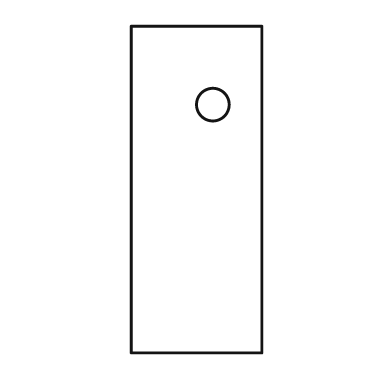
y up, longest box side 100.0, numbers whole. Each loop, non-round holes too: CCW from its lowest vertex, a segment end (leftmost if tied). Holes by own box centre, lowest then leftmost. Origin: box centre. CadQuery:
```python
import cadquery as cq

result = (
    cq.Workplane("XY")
    .moveTo(-20.0, -50.0)
    .lineTo(20.0, -50.0)
    .lineTo(20.0, 50.0)
    .lineTo(-20.0, 50.0)
    .close()
    .moveTo(5.0, 26.0)
    .circle(5.0)
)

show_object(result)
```